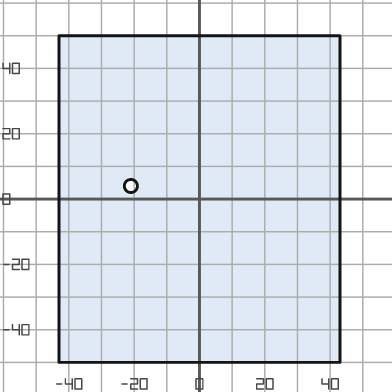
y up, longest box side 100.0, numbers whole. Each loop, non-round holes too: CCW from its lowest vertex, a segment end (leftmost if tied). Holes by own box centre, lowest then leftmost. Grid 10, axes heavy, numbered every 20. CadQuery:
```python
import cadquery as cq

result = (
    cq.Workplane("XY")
    .moveTo(-43.0, -50.0)
    .lineTo(43.0, -50.0)
    .lineTo(43.0, 50.0)
    .lineTo(-43.0, 50.0)
    .close()
    .moveTo(-21.0, 4.0)
    .circle(2.0)
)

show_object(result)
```